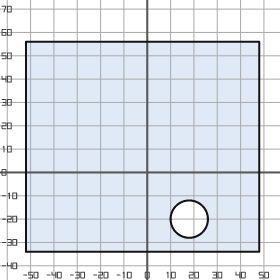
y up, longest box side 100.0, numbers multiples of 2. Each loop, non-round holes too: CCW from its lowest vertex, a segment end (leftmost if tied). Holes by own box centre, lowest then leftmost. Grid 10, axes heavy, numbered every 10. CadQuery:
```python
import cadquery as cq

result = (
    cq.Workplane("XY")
    .moveTo(-52.0, -34.0)
    .lineTo(48.0, -34.0)
    .lineTo(48.0, 56.0)
    .lineTo(-52.0, 56.0)
    .close()
    .moveTo(18.0, -20.0)
    .circle(8.0)
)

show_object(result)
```